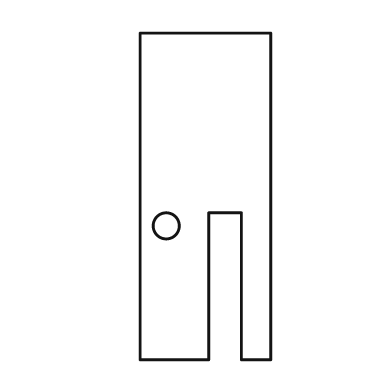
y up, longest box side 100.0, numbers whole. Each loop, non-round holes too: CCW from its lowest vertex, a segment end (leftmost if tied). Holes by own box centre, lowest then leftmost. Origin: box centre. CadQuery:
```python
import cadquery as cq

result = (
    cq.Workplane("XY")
    .moveTo(-20.0, -50.0)
    .lineTo(1.0, -50.0)
    .lineTo(1.0, -5.0)
    .lineTo(11.0, -5.0)
    .lineTo(11.0, -50.0)
    .lineTo(20.0, -50.0)
    .lineTo(20.0, 50.0)
    .lineTo(-20.0, 50.0)
    .close()
    .moveTo(-12.0, -9.0)
    .circle(4.0)
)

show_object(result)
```